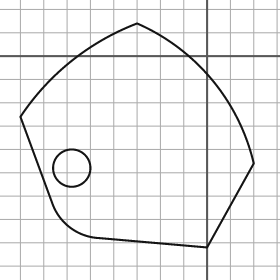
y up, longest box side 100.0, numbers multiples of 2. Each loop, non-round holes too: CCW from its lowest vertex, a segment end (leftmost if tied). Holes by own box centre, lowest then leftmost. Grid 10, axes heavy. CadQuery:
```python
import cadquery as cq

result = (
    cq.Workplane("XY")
    .moveTo(0.0, -82.0)
    .lineTo(20.0, -46.0)
    .threePointArc((2.0, -10.0), (-30.0, 14.0))
    .threePointArc((-58.0, -2.0), (-80.0, -26.0))
    .lineTo(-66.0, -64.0)
    .threePointArc((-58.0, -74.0), (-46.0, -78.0))
    .close()
    .moveTo(-58.0, -48.0)
    .circle(8.0)
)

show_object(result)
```